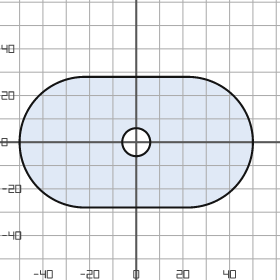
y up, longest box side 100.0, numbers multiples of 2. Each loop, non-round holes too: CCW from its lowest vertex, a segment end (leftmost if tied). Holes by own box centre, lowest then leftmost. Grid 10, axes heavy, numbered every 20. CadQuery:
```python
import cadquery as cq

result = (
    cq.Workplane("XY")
    .moveTo(-22.0, -28.0)
    .lineTo(22.0, -28.0)
    .threePointArc((50.0, 0.0), (22.0, 28.0))
    .lineTo(-22.0, 28.0)
    .threePointArc((-50.0, 0.0), (-22.0, -28.0))
    .close()
    .moveTo(0.0, 0.0)
    .circle(6.0)
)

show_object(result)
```